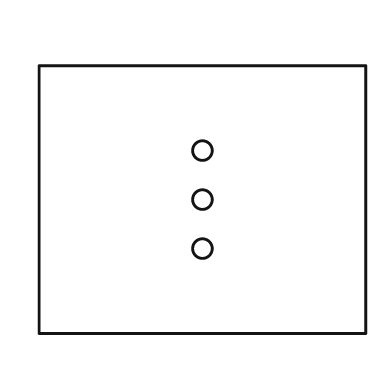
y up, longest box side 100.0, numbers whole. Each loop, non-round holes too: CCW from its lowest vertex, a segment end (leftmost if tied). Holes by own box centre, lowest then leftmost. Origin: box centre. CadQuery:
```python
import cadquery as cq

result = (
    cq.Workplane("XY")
    .moveTo(-50.0, -41.0)
    .lineTo(50.0, -41.0)
    .lineTo(50.0, 41.0)
    .lineTo(-50.0, 41.0)
    .close()
    .moveTo(0.0, -15.0)
    .circle(3.0)
    .moveTo(0.0, 0.0)
    .circle(3.0)
    .moveTo(0.0, 15.0)
    .circle(3.0)
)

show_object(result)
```